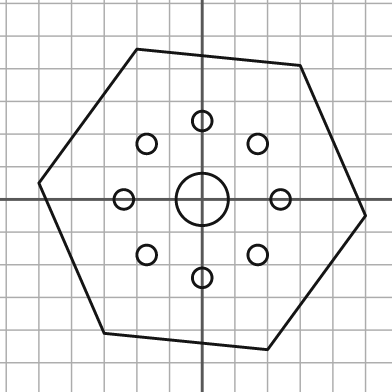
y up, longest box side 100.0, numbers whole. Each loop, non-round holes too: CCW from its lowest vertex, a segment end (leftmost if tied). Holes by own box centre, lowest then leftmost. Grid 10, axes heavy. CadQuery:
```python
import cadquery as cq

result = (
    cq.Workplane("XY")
    .moveTo(20.0, -46.0)
    .lineTo(50.0, -5.0)
    .lineTo(30.0, 41.0)
    .lineTo(-20.0, 46.0)
    .lineTo(-50.0, 5.0)
    .lineTo(-30.0, -41.0)
    .close()
    .moveTo(0.0, -24.0)
    .circle(3.0)
    .moveTo(-17.0, -17.0)
    .circle(3.0)
    .moveTo(17.0, -17.0)
    .circle(3.0)
    .moveTo(-24.0, 0.0)
    .circle(3.0)
    .moveTo(0.0, 0.0)
    .circle(8.0)
    .moveTo(24.0, 0.0)
    .circle(3.0)
    .moveTo(-17.0, 17.0)
    .circle(3.0)
    .moveTo(17.0, 17.0)
    .circle(3.0)
    .moveTo(0.0, 24.0)
    .circle(3.0)
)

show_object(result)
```